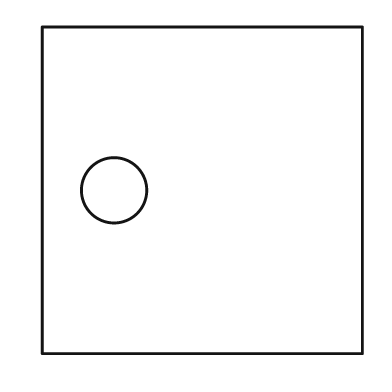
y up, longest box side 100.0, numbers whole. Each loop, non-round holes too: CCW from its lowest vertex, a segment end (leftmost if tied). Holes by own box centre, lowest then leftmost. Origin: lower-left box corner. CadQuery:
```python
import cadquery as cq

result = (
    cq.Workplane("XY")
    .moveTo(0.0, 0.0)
    .lineTo(98.0, 0.0)
    .lineTo(98.0, 100.0)
    .lineTo(0.0, 100.0)
    .close()
    .moveTo(22.0, 50.0)
    .circle(10.0)
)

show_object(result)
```